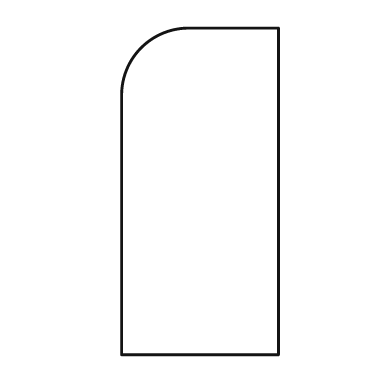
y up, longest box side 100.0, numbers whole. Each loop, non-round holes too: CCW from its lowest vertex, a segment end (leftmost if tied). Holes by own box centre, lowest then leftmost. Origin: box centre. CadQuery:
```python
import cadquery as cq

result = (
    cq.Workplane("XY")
    .moveTo(-24.0, -50.0)
    .lineTo(24.0, -50.0)
    .lineTo(24.0, 50.0)
    .lineTo(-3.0, 50.0)
    .threePointArc((-18.0, 44.0), (-24.0, 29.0))
    .close()
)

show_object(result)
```